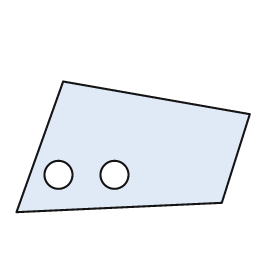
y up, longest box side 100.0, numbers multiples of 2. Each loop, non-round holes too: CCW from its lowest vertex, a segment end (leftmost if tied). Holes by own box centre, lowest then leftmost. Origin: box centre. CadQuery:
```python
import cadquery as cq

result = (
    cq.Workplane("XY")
    .moveTo(-50.0, -28.0)
    .lineTo(38.0, -24.0)
    .lineTo(50.0, 14.0)
    .lineTo(-30.0, 28.0)
    .close()
    .moveTo(-32.0, -12.0)
    .circle(6.0)
    .moveTo(-8.0, -12.0)
    .circle(6.0)
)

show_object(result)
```